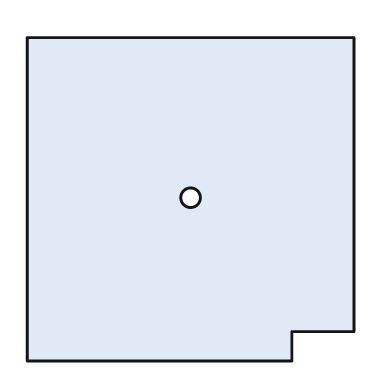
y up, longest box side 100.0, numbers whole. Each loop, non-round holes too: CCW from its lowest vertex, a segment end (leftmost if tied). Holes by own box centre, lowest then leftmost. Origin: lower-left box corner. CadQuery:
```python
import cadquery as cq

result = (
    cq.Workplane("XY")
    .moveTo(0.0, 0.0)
    .lineTo(81.0, 0.0)
    .lineTo(81.0, 9.0)
    .lineTo(100.0, 9.0)
    .lineTo(100.0, 99.0)
    .lineTo(0.0, 99.0)
    .close()
    .moveTo(50.0, 50.0)
    .circle(3.0)
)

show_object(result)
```